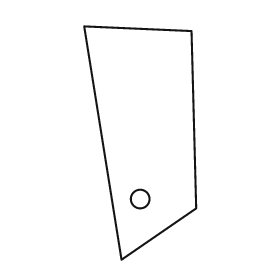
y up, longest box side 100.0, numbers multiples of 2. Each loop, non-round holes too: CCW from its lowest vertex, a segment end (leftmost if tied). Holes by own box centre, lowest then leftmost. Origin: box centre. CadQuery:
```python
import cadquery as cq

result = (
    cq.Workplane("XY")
    .moveTo(-8.0, -50.0)
    .lineTo(24.0, -28.0)
    .lineTo(22.0, 48.0)
    .lineTo(-24.0, 50.0)
    .close()
    .moveTo(0.0, -24.0)
    .circle(4.0)
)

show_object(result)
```